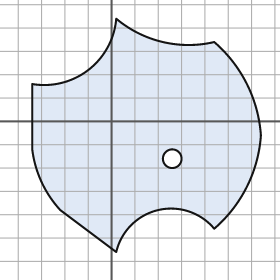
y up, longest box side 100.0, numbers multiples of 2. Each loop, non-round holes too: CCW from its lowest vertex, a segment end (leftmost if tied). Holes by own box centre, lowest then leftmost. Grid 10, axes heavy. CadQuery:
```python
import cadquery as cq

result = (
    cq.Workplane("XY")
    .moveTo(2.0, -56.0)
    .threePointArc((20.0, -38.0), (44.0, -46.0))
    .threePointArc((58.0, -28.0), (64.0, -6.0))
    .threePointArc((58.0, 16.0), (44.0, 34.0))
    .threePointArc((22.0, 34.0), (2.0, 44.0))
    .threePointArc((-10.0, 22.0), (-34.0, 16.0))
    .lineTo(-34.0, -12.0)
    .threePointArc((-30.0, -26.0), (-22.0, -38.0))
    .close()
    .moveTo(26.0, -16.0)
    .circle(4.0)
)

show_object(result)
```